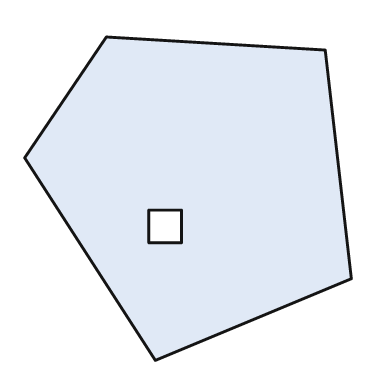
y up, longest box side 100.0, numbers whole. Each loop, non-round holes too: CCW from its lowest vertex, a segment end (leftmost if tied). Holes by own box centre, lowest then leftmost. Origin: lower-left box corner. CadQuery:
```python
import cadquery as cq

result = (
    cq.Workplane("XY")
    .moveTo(40.0, 0.0)
    .lineTo(100.0, 25.0)
    .lineTo(92.0, 95.0)
    .lineTo(25.0, 99.0)
    .lineTo(0.0, 62.0)
    .close()
    .moveTo(38.0, 36.0)
    .lineTo(48.0, 36.0)
    .lineTo(48.0, 46.0)
    .lineTo(38.0, 46.0)
    .close()
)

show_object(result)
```